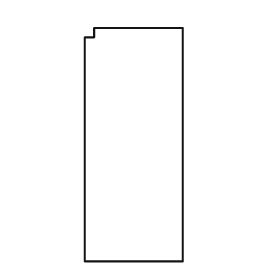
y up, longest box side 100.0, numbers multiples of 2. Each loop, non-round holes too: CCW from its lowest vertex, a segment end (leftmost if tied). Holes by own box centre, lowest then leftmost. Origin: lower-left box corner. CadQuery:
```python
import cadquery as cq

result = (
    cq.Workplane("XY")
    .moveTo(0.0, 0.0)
    .lineTo(42.0, 0.0)
    .lineTo(42.0, 100.0)
    .lineTo(4.0, 100.0)
    .lineTo(4.0, 96.0)
    .lineTo(0.0, 96.0)
    .close()
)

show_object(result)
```